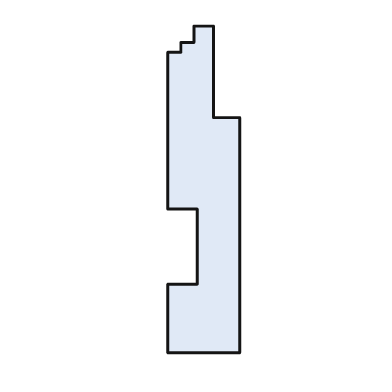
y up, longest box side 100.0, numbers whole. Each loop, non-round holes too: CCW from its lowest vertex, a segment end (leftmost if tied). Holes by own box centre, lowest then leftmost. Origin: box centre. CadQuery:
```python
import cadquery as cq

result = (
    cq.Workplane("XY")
    .moveTo(-11.0, -50.0)
    .lineTo(11.0, -50.0)
    .lineTo(11.0, 22.0)
    .lineTo(3.0, 22.0)
    .lineTo(3.0, 50.0)
    .lineTo(-3.0, 50.0)
    .lineTo(-3.0, 45.0)
    .lineTo(-7.0, 45.0)
    .lineTo(-7.0, 42.0)
    .lineTo(-11.0, 42.0)
    .lineTo(-11.0, -6.0)
    .lineTo(-2.0, -6.0)
    .lineTo(-2.0, -29.0)
    .lineTo(-11.0, -29.0)
    .close()
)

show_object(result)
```